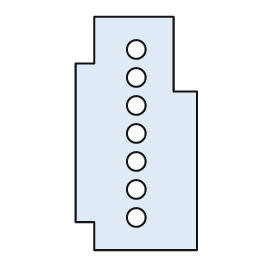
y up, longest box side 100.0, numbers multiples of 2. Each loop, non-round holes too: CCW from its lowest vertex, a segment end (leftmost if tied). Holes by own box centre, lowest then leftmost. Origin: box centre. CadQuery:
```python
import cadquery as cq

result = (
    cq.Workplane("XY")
    .moveTo(-18.0, -50.0)
    .lineTo(26.0, -50.0)
    .lineTo(26.0, 18.0)
    .lineTo(16.0, 18.0)
    .lineTo(16.0, 50.0)
    .lineTo(-18.0, 50.0)
    .lineTo(-18.0, 30.0)
    .lineTo(-26.0, 30.0)
    .lineTo(-26.0, -38.0)
    .lineTo(-18.0, -38.0)
    .close()
    .moveTo(0.0, -36.0)
    .circle(4.0)
    .moveTo(0.0, -24.0)
    .circle(4.0)
    .moveTo(0.0, -12.0)
    .circle(4.0)
    .moveTo(0.0, 0.0)
    .circle(4.0)
    .moveTo(0.0, 12.0)
    .circle(4.0)
    .moveTo(0.0, 24.0)
    .circle(4.0)
    .moveTo(0.0, 36.0)
    .circle(4.0)
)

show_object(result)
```